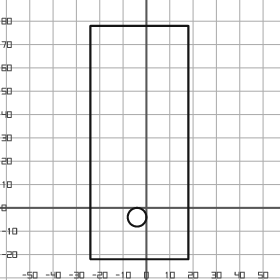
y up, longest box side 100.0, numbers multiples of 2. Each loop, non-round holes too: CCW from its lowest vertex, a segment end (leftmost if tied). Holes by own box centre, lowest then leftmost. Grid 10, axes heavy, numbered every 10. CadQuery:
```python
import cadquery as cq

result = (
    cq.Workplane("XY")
    .moveTo(-24.0, -22.0)
    .lineTo(18.0, -22.0)
    .lineTo(18.0, 78.0)
    .lineTo(-24.0, 78.0)
    .close()
    .moveTo(-4.0, -4.0)
    .circle(4.0)
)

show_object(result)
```